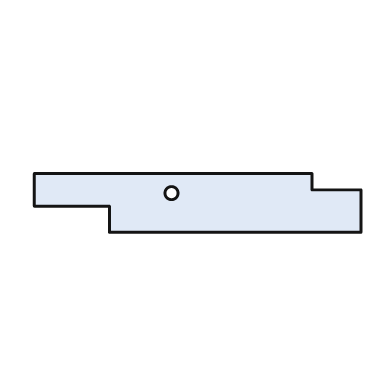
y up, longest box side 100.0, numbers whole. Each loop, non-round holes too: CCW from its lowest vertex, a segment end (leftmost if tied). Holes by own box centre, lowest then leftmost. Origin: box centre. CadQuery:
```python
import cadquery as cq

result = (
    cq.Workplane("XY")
    .moveTo(-27.0, -9.0)
    .lineTo(50.0, -9.0)
    .lineTo(50.0, 4.0)
    .lineTo(35.0, 4.0)
    .lineTo(35.0, 9.0)
    .lineTo(-50.0, 9.0)
    .lineTo(-50.0, -1.0)
    .lineTo(-27.0, -1.0)
    .close()
    .moveTo(-8.0, 3.0)
    .circle(2.0)
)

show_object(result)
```